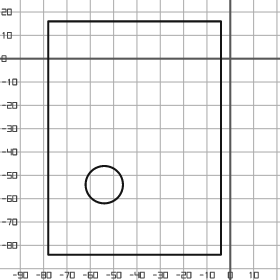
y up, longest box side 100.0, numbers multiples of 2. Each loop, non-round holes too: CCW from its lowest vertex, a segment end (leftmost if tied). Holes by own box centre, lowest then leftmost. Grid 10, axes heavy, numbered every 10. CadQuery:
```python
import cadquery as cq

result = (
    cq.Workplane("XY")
    .moveTo(-78.0, -84.0)
    .lineTo(-4.0, -84.0)
    .lineTo(-4.0, 16.0)
    .lineTo(-78.0, 16.0)
    .close()
    .moveTo(-54.0, -54.0)
    .circle(8.0)
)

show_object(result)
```